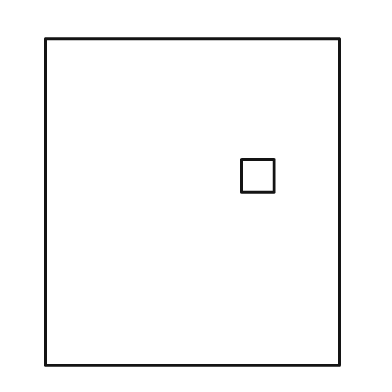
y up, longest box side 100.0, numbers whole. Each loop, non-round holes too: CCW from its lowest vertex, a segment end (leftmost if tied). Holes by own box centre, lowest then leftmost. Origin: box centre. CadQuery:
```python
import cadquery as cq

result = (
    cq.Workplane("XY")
    .moveTo(-45.0, -50.0)
    .lineTo(45.0, -50.0)
    .lineTo(45.0, 50.0)
    .lineTo(-45.0, 50.0)
    .close()
    .moveTo(15.0, 3.0)
    .lineTo(25.0, 3.0)
    .lineTo(25.0, 13.0)
    .lineTo(15.0, 13.0)
    .close()
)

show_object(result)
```